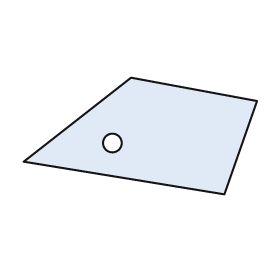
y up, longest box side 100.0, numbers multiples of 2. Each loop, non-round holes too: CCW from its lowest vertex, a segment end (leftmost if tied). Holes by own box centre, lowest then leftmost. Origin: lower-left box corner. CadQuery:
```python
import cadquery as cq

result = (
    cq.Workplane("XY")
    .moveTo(86.0, 0.0)
    .lineTo(100.0, 40.0)
    .lineTo(46.0, 50.0)
    .lineTo(0.0, 14.0)
    .close()
    .moveTo(38.0, 22.0)
    .circle(4.0)
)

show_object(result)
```